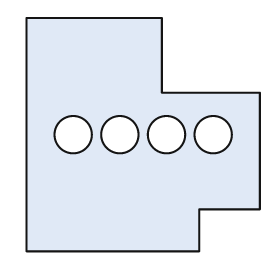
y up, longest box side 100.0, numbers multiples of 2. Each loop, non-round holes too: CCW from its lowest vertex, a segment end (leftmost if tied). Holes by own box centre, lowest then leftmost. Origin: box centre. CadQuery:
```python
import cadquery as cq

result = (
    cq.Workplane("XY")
    .moveTo(-50.0, -50.0)
    .lineTo(24.0, -50.0)
    .lineTo(24.0, -32.0)
    .lineTo(50.0, -32.0)
    .lineTo(50.0, 18.0)
    .lineTo(8.0, 18.0)
    .lineTo(8.0, 50.0)
    .lineTo(-50.0, 50.0)
    .close()
    .moveTo(-30.0, 0.0)
    .circle(8.0)
    .moveTo(-10.0, 0.0)
    .circle(8.0)
    .moveTo(10.0, 0.0)
    .circle(8.0)
    .moveTo(30.0, 0.0)
    .circle(8.0)
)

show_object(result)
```